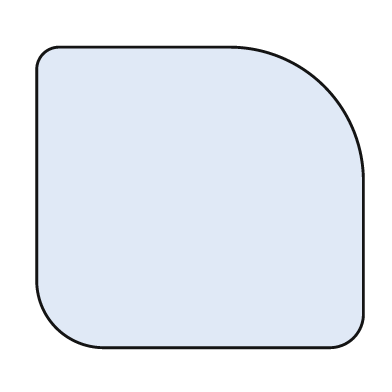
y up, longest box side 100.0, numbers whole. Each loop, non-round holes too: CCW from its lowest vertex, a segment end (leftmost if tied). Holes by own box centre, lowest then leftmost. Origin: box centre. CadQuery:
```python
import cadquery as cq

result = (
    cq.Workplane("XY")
    .moveTo(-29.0, -46.0)
    .lineTo(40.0, -46.0)
    .threePointArc((47.0, -43.0), (50.0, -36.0))
    .lineTo(50.0, 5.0)
    .threePointArc((38.0, 34.0), (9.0, 46.0))
    .lineTo(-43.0, 46.0)
    .threePointArc((-48.0, 44.0), (-50.0, 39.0))
    .lineTo(-50.0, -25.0)
    .threePointArc((-44.0, -40.0), (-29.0, -46.0))
    .close()
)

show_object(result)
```